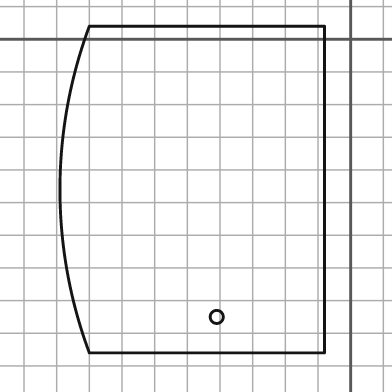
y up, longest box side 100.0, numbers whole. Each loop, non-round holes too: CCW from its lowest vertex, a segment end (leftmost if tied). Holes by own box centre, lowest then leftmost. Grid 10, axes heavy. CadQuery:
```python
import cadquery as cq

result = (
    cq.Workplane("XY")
    .moveTo(-80.0, -96.0)
    .lineTo(-8.0, -96.0)
    .lineTo(-8.0, 4.0)
    .lineTo(-80.0, 4.0)
    .threePointArc((-89.0, -46.0), (-80.0, -96.0))
    .close()
    .moveTo(-41.0, -85.0)
    .circle(2.0)
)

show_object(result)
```